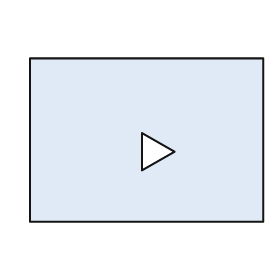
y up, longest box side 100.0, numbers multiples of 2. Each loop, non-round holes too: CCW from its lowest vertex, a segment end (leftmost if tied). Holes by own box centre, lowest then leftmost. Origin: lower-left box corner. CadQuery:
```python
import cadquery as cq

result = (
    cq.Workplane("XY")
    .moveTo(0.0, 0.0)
    .lineTo(100.0, 0.0)
    .lineTo(100.0, 70.0)
    .lineTo(0.0, 70.0)
    .close()
    .moveTo(48.0, 22.0)
    .lineTo(62.0, 30.0)
    .lineTo(48.0, 38.0)
    .close()
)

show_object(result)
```